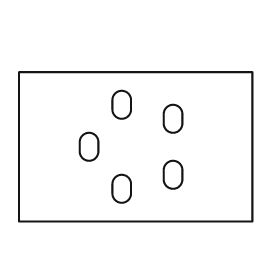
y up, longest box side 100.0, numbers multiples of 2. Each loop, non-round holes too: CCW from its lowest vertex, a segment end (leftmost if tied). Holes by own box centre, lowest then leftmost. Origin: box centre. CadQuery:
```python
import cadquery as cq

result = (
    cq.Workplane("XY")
    .moveTo(-50.0, -32.0)
    .lineTo(50.0, -32.0)
    .lineTo(50.0, 32.0)
    .lineTo(-50.0, 32.0)
    .close()
    .moveTo(-10.0, -20.0)
    .threePointArc((-6.0, -24.0), (-2.0, -20.0))
    .lineTo(-2.0, -16.0)
    .threePointArc((-6.0, -12.0), (-10.0, -16.0))
    .close()
    .moveTo(12.0, -14.0)
    .threePointArc((16.0, -18.0), (20.0, -14.0))
    .lineTo(20.0, -10.0)
    .threePointArc((16.0, -6.0), (12.0, -10.0))
    .close()
    .moveTo(-24.0, -2.0)
    .threePointArc((-20.0, -6.0), (-16.0, -2.0))
    .lineTo(-16.0, 2.0)
    .threePointArc((-20.0, 6.0), (-24.0, 2.0))
    .close()
    .moveTo(12.0, 10.0)
    .threePointArc((16.0, 6.0), (20.0, 10.0))
    .lineTo(20.0, 14.0)
    .threePointArc((16.0, 18.0), (12.0, 14.0))
    .close()
    .moveTo(-10.0, 16.0)
    .threePointArc((-6.0, 12.0), (-2.0, 16.0))
    .lineTo(-2.0, 20.0)
    .threePointArc((-6.0, 24.0), (-10.0, 20.0))
    .close()
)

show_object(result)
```